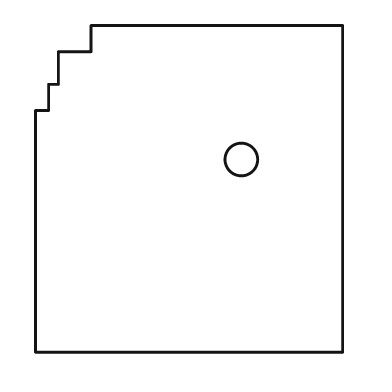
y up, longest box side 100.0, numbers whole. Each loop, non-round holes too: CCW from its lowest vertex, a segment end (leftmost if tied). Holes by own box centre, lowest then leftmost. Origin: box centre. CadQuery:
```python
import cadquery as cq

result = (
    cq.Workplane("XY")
    .moveTo(-47.0, -50.0)
    .lineTo(47.0, -50.0)
    .lineTo(47.0, 50.0)
    .lineTo(-30.0, 50.0)
    .lineTo(-30.0, 42.0)
    .lineTo(-40.0, 42.0)
    .lineTo(-40.0, 32.0)
    .lineTo(-43.0, 32.0)
    .lineTo(-43.0, 24.0)
    .lineTo(-47.0, 24.0)
    .close()
    .moveTo(16.0, 9.0)
    .circle(5.0)
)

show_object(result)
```